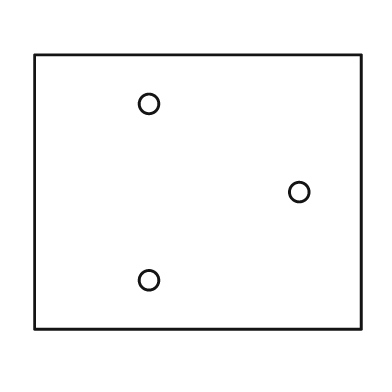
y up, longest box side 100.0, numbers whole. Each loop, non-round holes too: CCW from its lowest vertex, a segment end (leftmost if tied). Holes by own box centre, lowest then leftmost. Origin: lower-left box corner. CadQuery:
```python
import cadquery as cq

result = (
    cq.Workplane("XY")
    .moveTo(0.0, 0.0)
    .lineTo(100.0, 0.0)
    .lineTo(100.0, 84.0)
    .lineTo(0.0, 84.0)
    .close()
    .moveTo(35.0, 15.0)
    .circle(3.0)
    .moveTo(81.0, 42.0)
    .circle(3.0)
    .moveTo(35.0, 69.0)
    .circle(3.0)
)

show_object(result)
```